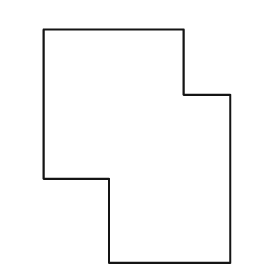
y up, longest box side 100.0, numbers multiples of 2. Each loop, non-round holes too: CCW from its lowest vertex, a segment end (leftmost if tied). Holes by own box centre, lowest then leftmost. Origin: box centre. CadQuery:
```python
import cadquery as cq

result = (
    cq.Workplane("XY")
    .moveTo(-12.0, -50.0)
    .lineTo(40.0, -50.0)
    .lineTo(40.0, 22.0)
    .lineTo(20.0, 22.0)
    .lineTo(20.0, 50.0)
    .lineTo(-40.0, 50.0)
    .lineTo(-40.0, -14.0)
    .lineTo(-12.0, -14.0)
    .close()
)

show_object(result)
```